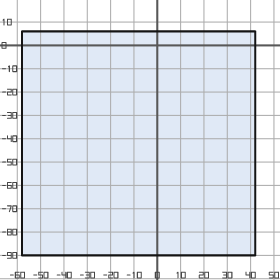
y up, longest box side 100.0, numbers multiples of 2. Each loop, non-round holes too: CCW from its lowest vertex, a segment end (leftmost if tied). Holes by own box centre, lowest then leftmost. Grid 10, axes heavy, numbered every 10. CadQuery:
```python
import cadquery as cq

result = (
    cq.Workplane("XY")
    .moveTo(-58.0, -90.0)
    .lineTo(42.0, -90.0)
    .lineTo(42.0, 6.0)
    .lineTo(-58.0, 6.0)
    .close()
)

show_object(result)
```